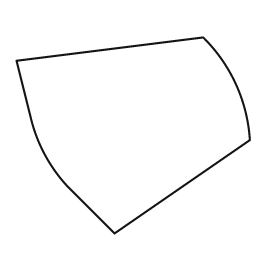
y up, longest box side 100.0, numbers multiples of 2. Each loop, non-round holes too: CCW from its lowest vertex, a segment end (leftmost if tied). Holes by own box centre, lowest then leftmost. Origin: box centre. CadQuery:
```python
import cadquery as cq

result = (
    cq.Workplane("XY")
    .moveTo(-8.0, -42.0)
    .lineTo(50.0, -2.0)
    .threePointArc((44.0, 22.0), (30.0, 42.0))
    .lineTo(-50.0, 32.0)
    .lineTo(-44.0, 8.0)
    .threePointArc((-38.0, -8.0), (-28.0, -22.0))
    .close()
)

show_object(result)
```